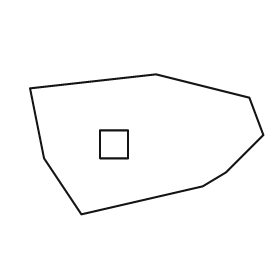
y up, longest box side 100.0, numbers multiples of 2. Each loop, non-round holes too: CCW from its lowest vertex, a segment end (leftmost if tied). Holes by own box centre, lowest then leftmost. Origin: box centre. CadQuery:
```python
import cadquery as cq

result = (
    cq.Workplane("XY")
    .moveTo(-28.0, -30.0)
    .lineTo(24.0, -18.0)
    .lineTo(34.0, -12.0)
    .lineTo(50.0, 4.0)
    .lineTo(44.0, 20.0)
    .lineTo(4.0, 30.0)
    .lineTo(-50.0, 24.0)
    .lineTo(-44.0, -6.0)
    .close()
    .moveTo(-20.0, -6.0)
    .lineTo(-8.0, -6.0)
    .lineTo(-8.0, 6.0)
    .lineTo(-20.0, 6.0)
    .close()
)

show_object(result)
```